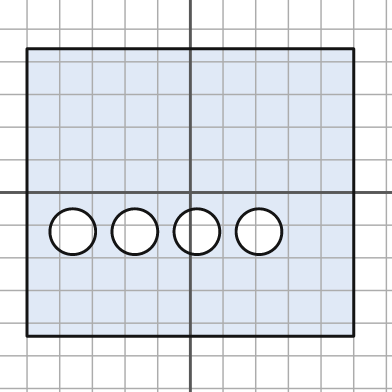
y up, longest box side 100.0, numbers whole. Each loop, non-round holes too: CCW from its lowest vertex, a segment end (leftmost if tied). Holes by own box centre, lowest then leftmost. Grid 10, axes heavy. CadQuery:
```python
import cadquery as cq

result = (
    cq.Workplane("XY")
    .moveTo(-50.0, -44.0)
    .lineTo(50.0, -44.0)
    .lineTo(50.0, 44.0)
    .lineTo(-50.0, 44.0)
    .close()
    .moveTo(-36.0, -12.0)
    .circle(7.0)
    .moveTo(-17.0, -12.0)
    .circle(7.0)
    .moveTo(2.0, -12.0)
    .circle(7.0)
    .moveTo(21.0, -12.0)
    .circle(7.0)
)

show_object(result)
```